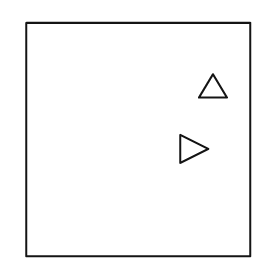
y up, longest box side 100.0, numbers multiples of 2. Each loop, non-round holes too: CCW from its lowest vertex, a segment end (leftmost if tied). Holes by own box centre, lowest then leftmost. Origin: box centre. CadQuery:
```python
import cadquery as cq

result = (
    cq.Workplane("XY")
    .moveTo(-48.0, -50.0)
    .lineTo(48.0, -50.0)
    .lineTo(48.0, 50.0)
    .lineTo(-48.0, 50.0)
    .close()
    .moveTo(18.0, -10.0)
    .lineTo(30.0, -4.0)
    .lineTo(18.0, 2.0)
    .close()
    .moveTo(26.0, 18.0)
    .lineTo(38.0, 18.0)
    .lineTo(32.0, 28.0)
    .close()
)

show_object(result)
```